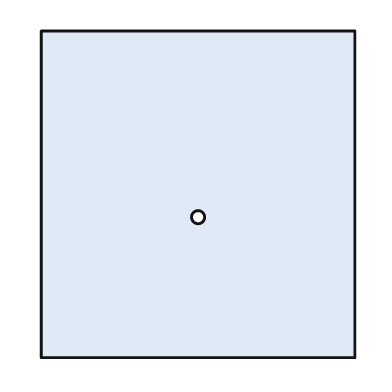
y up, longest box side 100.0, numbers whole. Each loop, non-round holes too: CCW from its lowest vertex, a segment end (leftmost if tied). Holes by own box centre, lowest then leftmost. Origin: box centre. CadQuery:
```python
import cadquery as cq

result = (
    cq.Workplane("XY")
    .moveTo(-48.0, -50.0)
    .lineTo(48.0, -50.0)
    .lineTo(48.0, 50.0)
    .lineTo(-48.0, 50.0)
    .close()
    .moveTo(0.0, -7.0)
    .circle(2.0)
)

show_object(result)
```